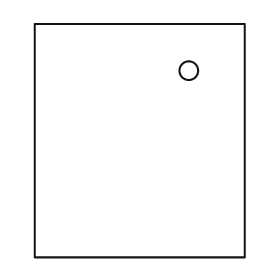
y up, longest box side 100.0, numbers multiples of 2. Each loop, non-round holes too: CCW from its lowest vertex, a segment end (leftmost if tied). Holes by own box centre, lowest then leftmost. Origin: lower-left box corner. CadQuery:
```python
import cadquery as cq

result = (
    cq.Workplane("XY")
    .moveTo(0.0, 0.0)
    .lineTo(90.0, 0.0)
    .lineTo(90.0, 100.0)
    .lineTo(0.0, 100.0)
    .close()
    .moveTo(66.0, 80.0)
    .circle(4.0)
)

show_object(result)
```